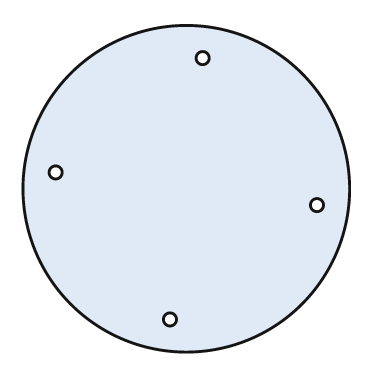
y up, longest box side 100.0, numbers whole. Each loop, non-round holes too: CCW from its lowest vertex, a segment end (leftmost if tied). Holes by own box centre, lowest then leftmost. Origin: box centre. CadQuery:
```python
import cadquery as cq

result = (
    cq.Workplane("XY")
    .moveTo(0.0, 0.0)
    .circle(50.0)
    .moveTo(-5.0, -40.0)
    .circle(2.0)
    .moveTo(40.0, -5.0)
    .circle(2.0)
    .moveTo(-40.0, 5.0)
    .circle(2.0)
    .moveTo(5.0, 40.0)
    .circle(2.0)
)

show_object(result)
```